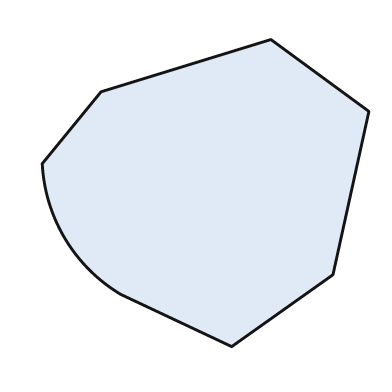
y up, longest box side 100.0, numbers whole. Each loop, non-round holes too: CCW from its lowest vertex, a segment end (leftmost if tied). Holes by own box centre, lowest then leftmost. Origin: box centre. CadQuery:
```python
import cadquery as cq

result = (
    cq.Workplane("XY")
    .moveTo(8.0, -47.0)
    .lineTo(39.0, -25.0)
    .lineTo(50.0, 25.0)
    .lineTo(20.0, 47.0)
    .lineTo(-32.0, 31.0)
    .lineTo(-50.0, 9.0)
    .threePointArc((-43.0, -14.0), (-26.0, -31.0))
    .close()
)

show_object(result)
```